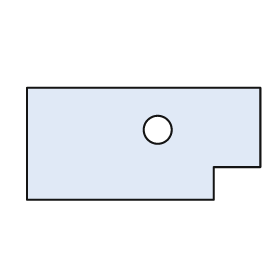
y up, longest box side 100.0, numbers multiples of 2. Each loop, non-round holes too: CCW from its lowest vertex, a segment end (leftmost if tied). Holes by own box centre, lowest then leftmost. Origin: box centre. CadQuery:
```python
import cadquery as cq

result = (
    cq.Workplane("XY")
    .moveTo(-50.0, -24.0)
    .lineTo(30.0, -24.0)
    .lineTo(30.0, -10.0)
    .lineTo(50.0, -10.0)
    .lineTo(50.0, 24.0)
    .lineTo(-50.0, 24.0)
    .close()
    .moveTo(6.0, 6.0)
    .circle(6.0)
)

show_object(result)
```